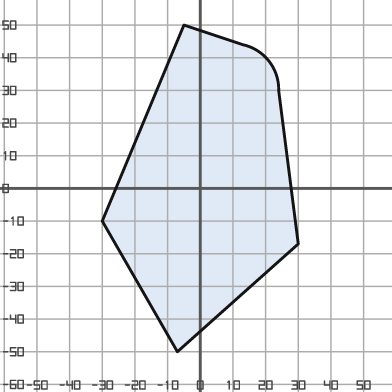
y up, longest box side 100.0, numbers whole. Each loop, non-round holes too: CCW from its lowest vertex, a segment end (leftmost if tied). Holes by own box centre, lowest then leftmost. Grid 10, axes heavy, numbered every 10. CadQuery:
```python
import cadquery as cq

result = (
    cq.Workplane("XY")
    .moveTo(-7.0, -50.0)
    .lineTo(30.0, -17.0)
    .lineTo(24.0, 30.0)
    .threePointArc((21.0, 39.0), (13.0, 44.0))
    .lineTo(-5.0, 50.0)
    .lineTo(-30.0, -10.0)
    .close()
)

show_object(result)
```